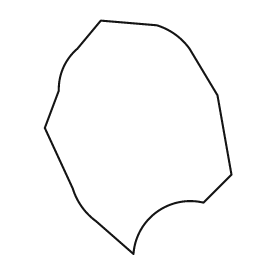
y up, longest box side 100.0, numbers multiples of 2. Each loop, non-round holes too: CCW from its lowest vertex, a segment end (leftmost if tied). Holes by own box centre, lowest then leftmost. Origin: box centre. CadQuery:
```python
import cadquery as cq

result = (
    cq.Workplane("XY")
    .moveTo(-2.0, -50.0)
    .threePointArc((8.0, -32.0), (28.0, -28.0))
    .lineTo(40.0, -16.0)
    .lineTo(34.0, 18.0)
    .lineTo(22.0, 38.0)
    .threePointArc((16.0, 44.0), (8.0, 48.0))
    .lineTo(-16.0, 50.0)
    .lineTo(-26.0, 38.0)
    .threePointArc((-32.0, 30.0), (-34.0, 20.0))
    .lineTo(-40.0, 4.0)
    .lineTo(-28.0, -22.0)
    .threePointArc((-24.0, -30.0), (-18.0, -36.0))
    .close()
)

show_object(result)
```